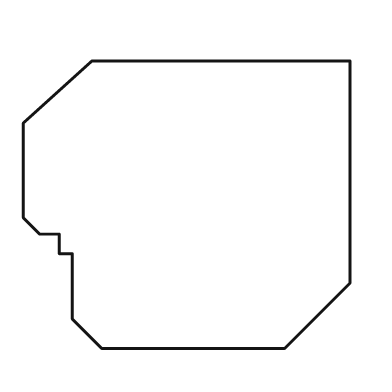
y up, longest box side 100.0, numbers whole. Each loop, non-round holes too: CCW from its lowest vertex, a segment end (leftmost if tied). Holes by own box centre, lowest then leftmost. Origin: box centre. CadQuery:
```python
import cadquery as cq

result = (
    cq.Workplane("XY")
    .moveTo(-26.0, -44.0)
    .lineTo(30.0, -44.0)
    .lineTo(50.0, -24.0)
    .lineTo(50.0, 44.0)
    .lineTo(-29.0, 44.0)
    .lineTo(-50.0, 25.0)
    .lineTo(-50.0, -4.0)
    .lineTo(-45.0, -9.0)
    .lineTo(-39.0, -9.0)
    .lineTo(-39.0, -15.0)
    .lineTo(-35.0, -15.0)
    .lineTo(-35.0, -35.0)
    .close()
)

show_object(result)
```